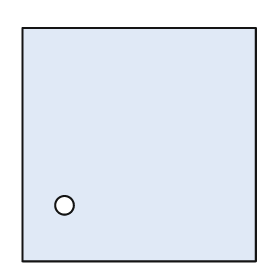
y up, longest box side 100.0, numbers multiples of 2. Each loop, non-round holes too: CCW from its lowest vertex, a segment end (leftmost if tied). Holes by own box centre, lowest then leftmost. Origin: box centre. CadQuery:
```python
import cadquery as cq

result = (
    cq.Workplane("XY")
    .moveTo(-50.0, -50.0)
    .lineTo(50.0, -50.0)
    .lineTo(50.0, 50.0)
    .lineTo(-50.0, 50.0)
    .close()
    .moveTo(-32.0, -26.0)
    .circle(4.0)
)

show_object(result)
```